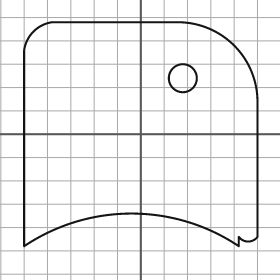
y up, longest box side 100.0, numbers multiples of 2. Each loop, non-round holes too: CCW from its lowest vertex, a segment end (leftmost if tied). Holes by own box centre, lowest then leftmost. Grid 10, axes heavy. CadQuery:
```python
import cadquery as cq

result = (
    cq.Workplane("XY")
    .moveTo(-50.0, -48.0)
    .threePointArc((-4.0, -34.0), (42.0, -48.0))
    .lineTo(42.0, -44.0)
    .threePointArc((46.0, -46.0), (50.0, -44.0))
    .lineTo(50.0, 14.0)
    .threePointArc((40.0, 38.0), (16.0, 48.0))
    .lineTo(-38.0, 48.0)
    .threePointArc((-46.0, 44.0), (-50.0, 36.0))
    .close()
    .moveTo(18.0, 24.0)
    .circle(6.0)
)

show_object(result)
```